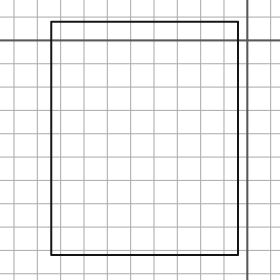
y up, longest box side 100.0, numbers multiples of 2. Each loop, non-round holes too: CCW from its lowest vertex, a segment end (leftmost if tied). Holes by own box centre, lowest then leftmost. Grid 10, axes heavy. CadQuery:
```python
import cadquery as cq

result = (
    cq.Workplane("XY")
    .moveTo(-84.0, -92.0)
    .lineTo(-4.0, -92.0)
    .lineTo(-4.0, 8.0)
    .lineTo(-84.0, 8.0)
    .close()
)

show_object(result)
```